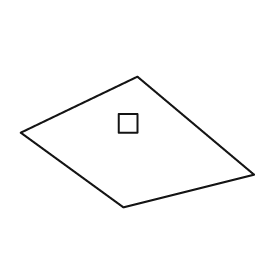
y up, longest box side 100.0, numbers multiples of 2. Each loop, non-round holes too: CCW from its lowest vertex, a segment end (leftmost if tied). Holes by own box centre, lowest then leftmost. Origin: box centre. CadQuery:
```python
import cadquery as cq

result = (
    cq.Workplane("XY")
    .moveTo(-6.0, -28.0)
    .lineTo(50.0, -14.0)
    .lineTo(0.0, 28.0)
    .lineTo(-50.0, 4.0)
    .close()
    .moveTo(-8.0, 4.0)
    .lineTo(0.0, 4.0)
    .lineTo(0.0, 12.0)
    .lineTo(-8.0, 12.0)
    .close()
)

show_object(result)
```